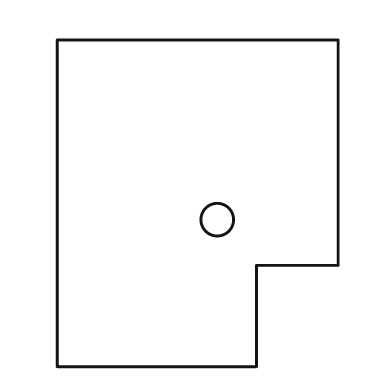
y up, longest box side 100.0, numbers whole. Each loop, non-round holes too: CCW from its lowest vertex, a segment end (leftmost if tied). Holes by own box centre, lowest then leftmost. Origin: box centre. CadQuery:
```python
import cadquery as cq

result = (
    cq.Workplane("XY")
    .moveTo(-43.0, -50.0)
    .lineTo(18.0, -50.0)
    .lineTo(18.0, -19.0)
    .lineTo(43.0, -19.0)
    .lineTo(43.0, 50.0)
    .lineTo(-43.0, 50.0)
    .close()
    .moveTo(6.0, -5.0)
    .circle(5.0)
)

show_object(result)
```